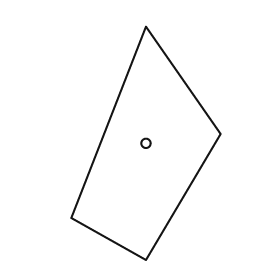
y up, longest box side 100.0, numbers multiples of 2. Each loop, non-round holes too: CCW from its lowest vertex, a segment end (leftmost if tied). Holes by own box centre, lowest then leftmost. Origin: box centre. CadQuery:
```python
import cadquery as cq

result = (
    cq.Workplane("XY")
    .moveTo(0.0, -50.0)
    .lineTo(32.0, 4.0)
    .lineTo(0.0, 50.0)
    .lineTo(-32.0, -32.0)
    .close()
    .moveTo(0.0, 0.0)
    .circle(2.0)
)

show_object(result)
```